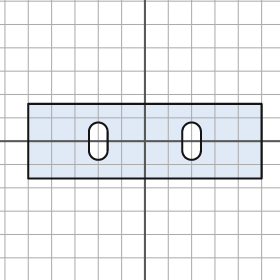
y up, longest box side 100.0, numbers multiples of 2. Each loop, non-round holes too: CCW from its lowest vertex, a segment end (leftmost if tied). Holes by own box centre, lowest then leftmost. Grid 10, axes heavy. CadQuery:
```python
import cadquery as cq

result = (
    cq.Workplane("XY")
    .moveTo(-50.0, -16.0)
    .lineTo(50.0, -16.0)
    .lineTo(50.0, 16.0)
    .lineTo(-50.0, 16.0)
    .close()
    .moveTo(-24.0, -4.0)
    .threePointArc((-20.0, -8.0), (-16.0, -4.0))
    .lineTo(-16.0, 4.0)
    .threePointArc((-20.0, 8.0), (-24.0, 4.0))
    .close()
    .moveTo(16.0, -4.0)
    .threePointArc((20.0, -8.0), (24.0, -4.0))
    .lineTo(24.0, 4.0)
    .threePointArc((20.0, 8.0), (16.0, 4.0))
    .close()
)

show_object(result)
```